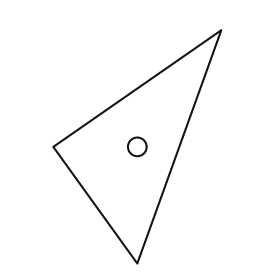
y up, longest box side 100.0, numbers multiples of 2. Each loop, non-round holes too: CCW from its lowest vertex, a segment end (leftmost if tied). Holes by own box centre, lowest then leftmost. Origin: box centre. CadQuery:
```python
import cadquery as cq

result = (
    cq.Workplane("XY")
    .moveTo(0.0, -50.0)
    .lineTo(36.0, 50.0)
    .lineTo(-36.0, 0.0)
    .close()
    .moveTo(0.0, 0.0)
    .circle(4.0)
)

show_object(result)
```